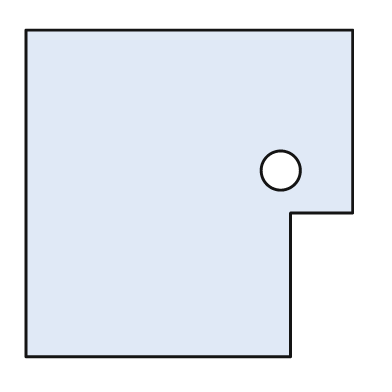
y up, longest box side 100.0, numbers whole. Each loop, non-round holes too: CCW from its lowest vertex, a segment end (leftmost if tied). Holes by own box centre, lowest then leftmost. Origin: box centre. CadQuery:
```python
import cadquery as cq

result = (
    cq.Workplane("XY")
    .moveTo(-50.0, -50.0)
    .lineTo(31.0, -50.0)
    .lineTo(31.0, -6.0)
    .lineTo(50.0, -6.0)
    .lineTo(50.0, 50.0)
    .lineTo(-50.0, 50.0)
    .close()
    .moveTo(28.0, 7.0)
    .circle(6.0)
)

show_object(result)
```